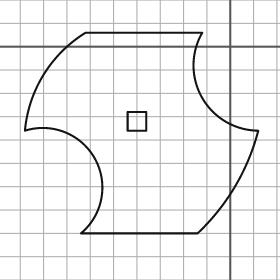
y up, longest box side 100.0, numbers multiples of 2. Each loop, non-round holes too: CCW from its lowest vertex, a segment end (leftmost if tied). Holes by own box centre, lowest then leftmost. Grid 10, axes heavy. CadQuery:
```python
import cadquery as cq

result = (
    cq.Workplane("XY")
    .moveTo(-64.0, -80.0)
    .lineTo(-14.0, -80.0)
    .threePointArc((2.0, -60.0), (12.0, -36.0))
    .threePointArc((-12.0, -22.0), (-12.0, 6.0))
    .lineTo(-62.0, 6.0)
    .threePointArc((-80.0, -12.0), (-88.0, -36.0))
    .threePointArc((-58.0, -48.0), (-64.0, -80.0))
    .close()
    .moveTo(-44.0, -36.0)
    .lineTo(-36.0, -36.0)
    .lineTo(-36.0, -28.0)
    .lineTo(-44.0, -28.0)
    .close()
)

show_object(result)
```